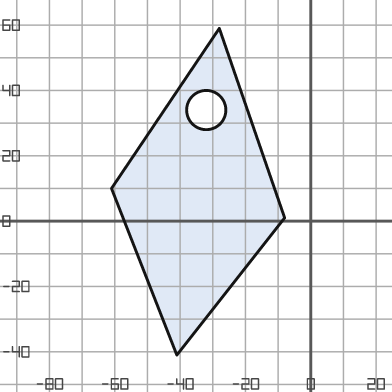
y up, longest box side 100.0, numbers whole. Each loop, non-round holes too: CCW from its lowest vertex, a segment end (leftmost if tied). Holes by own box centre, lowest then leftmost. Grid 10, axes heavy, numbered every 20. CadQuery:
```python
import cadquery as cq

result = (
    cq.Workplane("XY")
    .moveTo(-41.0, -41.0)
    .lineTo(-8.0, 1.0)
    .lineTo(-28.0, 59.0)
    .lineTo(-61.0, 10.0)
    .close()
    .moveTo(-32.0, 34.0)
    .circle(6.0)
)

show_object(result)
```